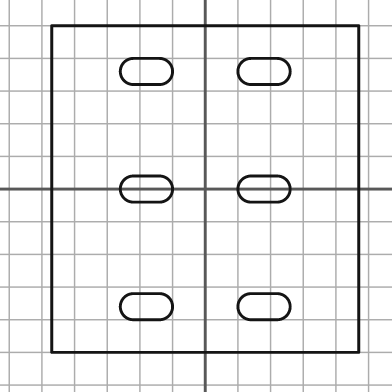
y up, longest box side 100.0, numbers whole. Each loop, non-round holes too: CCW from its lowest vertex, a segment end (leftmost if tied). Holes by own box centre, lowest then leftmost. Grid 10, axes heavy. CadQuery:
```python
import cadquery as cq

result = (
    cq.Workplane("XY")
    .moveTo(-47.0, -50.0)
    .lineTo(47.0, -50.0)
    .lineTo(47.0, 50.0)
    .lineTo(-47.0, 50.0)
    .close()
    .moveTo(-22.0, -40.0)
    .lineTo(-14.0, -40.0)
    .threePointArc((-10.0, -36.0), (-14.0, -32.0))
    .lineTo(-22.0, -32.0)
    .threePointArc((-26.0, -36.0), (-22.0, -40.0))
    .close()
    .moveTo(14.0, -40.0)
    .lineTo(22.0, -40.0)
    .threePointArc((26.0, -36.0), (22.0, -32.0))
    .lineTo(14.0, -32.0)
    .threePointArc((10.0, -36.0), (14.0, -40.0))
    .close()
    .moveTo(-22.0, -4.0)
    .lineTo(-14.0, -4.0)
    .threePointArc((-10.0, 0.0), (-14.0, 4.0))
    .lineTo(-22.0, 4.0)
    .threePointArc((-26.0, 0.0), (-22.0, -4.0))
    .close()
    .moveTo(14.0, -4.0)
    .lineTo(22.0, -4.0)
    .threePointArc((26.0, 0.0), (22.0, 4.0))
    .lineTo(14.0, 4.0)
    .threePointArc((10.0, 0.0), (14.0, -4.0))
    .close()
    .moveTo(-22.0, 32.0)
    .lineTo(-14.0, 32.0)
    .threePointArc((-10.0, 36.0), (-14.0, 40.0))
    .lineTo(-22.0, 40.0)
    .threePointArc((-26.0, 36.0), (-22.0, 32.0))
    .close()
    .moveTo(14.0, 32.0)
    .lineTo(22.0, 32.0)
    .threePointArc((26.0, 36.0), (22.0, 40.0))
    .lineTo(14.0, 40.0)
    .threePointArc((10.0, 36.0), (14.0, 32.0))
    .close()
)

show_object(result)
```